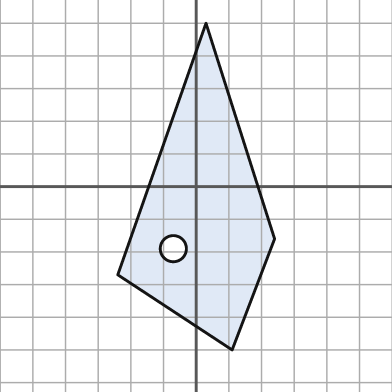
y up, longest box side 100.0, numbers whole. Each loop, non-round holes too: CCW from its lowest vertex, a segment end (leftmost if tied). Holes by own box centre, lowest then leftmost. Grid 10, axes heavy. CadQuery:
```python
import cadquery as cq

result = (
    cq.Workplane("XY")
    .moveTo(11.0, -50.0)
    .lineTo(24.0, -16.0)
    .lineTo(3.0, 50.0)
    .lineTo(-24.0, -27.0)
    .close()
    .moveTo(-7.0, -19.0)
    .circle(4.0)
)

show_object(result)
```